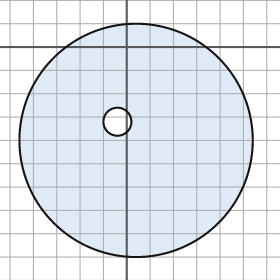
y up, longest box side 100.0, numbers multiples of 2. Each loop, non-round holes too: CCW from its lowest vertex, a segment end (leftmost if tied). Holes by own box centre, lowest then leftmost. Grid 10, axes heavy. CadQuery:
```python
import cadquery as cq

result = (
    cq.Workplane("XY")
    .moveTo(4.0, -40.0)
    .circle(50.0)
    .moveTo(-4.0, -32.0)
    .circle(6.0)
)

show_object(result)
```